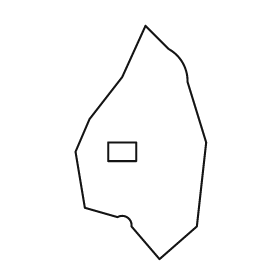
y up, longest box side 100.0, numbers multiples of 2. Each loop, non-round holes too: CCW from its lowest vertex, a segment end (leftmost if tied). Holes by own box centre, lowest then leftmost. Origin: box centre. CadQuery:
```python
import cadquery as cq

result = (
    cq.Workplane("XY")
    .moveTo(8.0, -50.0)
    .lineTo(24.0, -36.0)
    .lineTo(28.0, 0.0)
    .lineTo(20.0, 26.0)
    .threePointArc((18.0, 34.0), (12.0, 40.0))
    .lineTo(2.0, 50.0)
    .lineTo(-8.0, 28.0)
    .lineTo(-22.0, 10.0)
    .lineTo(-28.0, -4.0)
    .lineTo(-24.0, -28.0)
    .lineTo(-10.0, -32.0)
    .threePointArc((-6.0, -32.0), (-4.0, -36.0))
    .close()
    .moveTo(-14.0, -8.0)
    .lineTo(-2.0, -8.0)
    .lineTo(-2.0, 0.0)
    .lineTo(-14.0, 0.0)
    .close()
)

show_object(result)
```